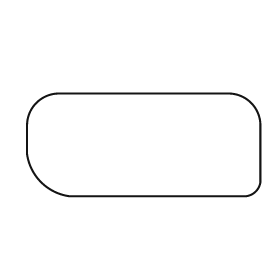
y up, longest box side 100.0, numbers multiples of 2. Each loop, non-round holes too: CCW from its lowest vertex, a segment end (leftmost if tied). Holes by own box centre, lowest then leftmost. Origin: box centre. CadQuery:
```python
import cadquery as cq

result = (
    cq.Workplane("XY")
    .moveTo(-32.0, -22.0)
    .lineTo(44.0, -22.0)
    .threePointArc((48.0, -20.0), (50.0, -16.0))
    .lineTo(50.0, 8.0)
    .threePointArc((46.0, 18.0), (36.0, 22.0))
    .lineTo(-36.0, 22.0)
    .threePointArc((-46.0, 18.0), (-50.0, 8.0))
    .lineTo(-50.0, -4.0)
    .threePointArc((-44.0, -16.0), (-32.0, -22.0))
    .close()
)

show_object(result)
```